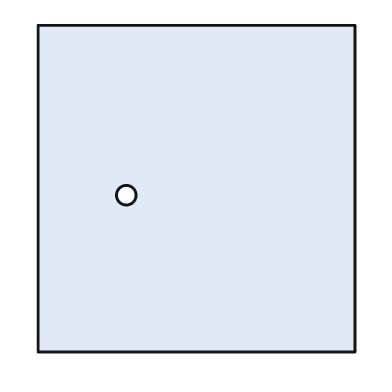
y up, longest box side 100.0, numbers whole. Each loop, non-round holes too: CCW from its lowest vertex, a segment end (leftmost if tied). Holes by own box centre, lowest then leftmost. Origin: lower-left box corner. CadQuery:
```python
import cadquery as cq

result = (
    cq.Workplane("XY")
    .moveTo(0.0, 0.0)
    .lineTo(97.0, 0.0)
    .lineTo(97.0, 100.0)
    .lineTo(0.0, 100.0)
    .close()
    .moveTo(27.0, 48.0)
    .circle(3.0)
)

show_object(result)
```